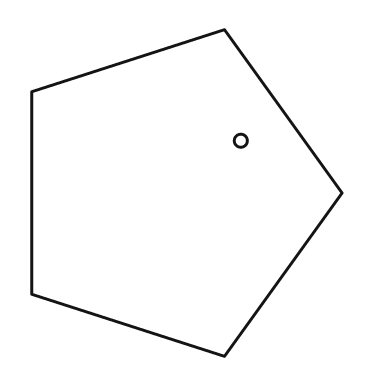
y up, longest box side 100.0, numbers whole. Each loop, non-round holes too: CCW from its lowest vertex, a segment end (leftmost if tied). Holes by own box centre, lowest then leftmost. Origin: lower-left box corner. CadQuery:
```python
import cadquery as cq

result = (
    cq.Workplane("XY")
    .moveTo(59.0, 0.0)
    .lineTo(95.0, 50.0)
    .lineTo(59.0, 100.0)
    .lineTo(0.0, 81.0)
    .lineTo(0.0, 19.0)
    .close()
    .moveTo(64.0, 66.0)
    .circle(2.0)
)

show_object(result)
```